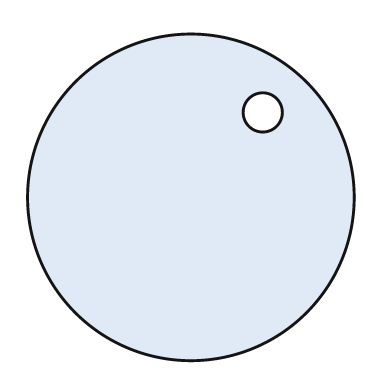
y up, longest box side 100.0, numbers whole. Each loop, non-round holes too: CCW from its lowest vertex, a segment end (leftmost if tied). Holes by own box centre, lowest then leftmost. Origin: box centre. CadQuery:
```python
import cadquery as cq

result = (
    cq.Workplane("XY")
    .moveTo(0.0, 0.0)
    .circle(50.0)
    .moveTo(22.0, 26.0)
    .circle(6.0)
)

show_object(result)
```